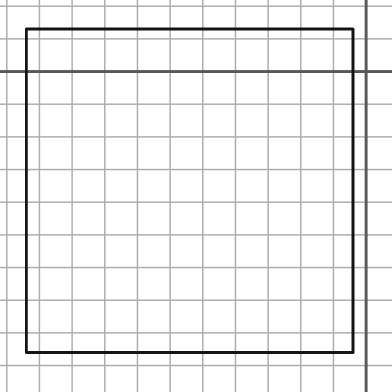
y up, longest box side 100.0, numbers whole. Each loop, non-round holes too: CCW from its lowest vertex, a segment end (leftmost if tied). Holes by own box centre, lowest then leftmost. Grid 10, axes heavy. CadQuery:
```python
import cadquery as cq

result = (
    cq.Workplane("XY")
    .moveTo(-104.0, -86.0)
    .lineTo(-4.0, -86.0)
    .lineTo(-4.0, 13.0)
    .lineTo(-104.0, 13.0)
    .close()
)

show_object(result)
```